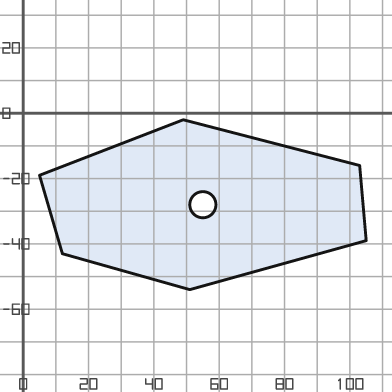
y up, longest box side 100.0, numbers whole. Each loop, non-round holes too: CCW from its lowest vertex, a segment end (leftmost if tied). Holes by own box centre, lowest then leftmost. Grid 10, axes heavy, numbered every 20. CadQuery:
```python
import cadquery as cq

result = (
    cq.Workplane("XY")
    .moveTo(51.0, -54.0)
    .lineTo(105.0, -39.0)
    .lineTo(103.0, -16.0)
    .lineTo(49.0, -2.0)
    .lineTo(5.0, -19.0)
    .lineTo(12.0, -43.0)
    .close()
    .moveTo(55.0, -28.0)
    .circle(4.0)
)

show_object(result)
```